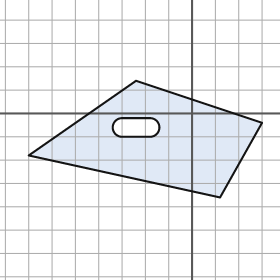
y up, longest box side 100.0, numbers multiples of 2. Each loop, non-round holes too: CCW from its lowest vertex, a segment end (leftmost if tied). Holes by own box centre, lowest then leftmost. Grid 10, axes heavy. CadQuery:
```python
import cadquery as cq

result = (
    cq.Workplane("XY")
    .moveTo(12.0, -36.0)
    .lineTo(30.0, -4.0)
    .lineTo(-24.0, 14.0)
    .lineTo(-70.0, -18.0)
    .close()
    .moveTo(-30.0, -10.0)
    .lineTo(-18.0, -10.0)
    .threePointArc((-14.0, -6.0), (-18.0, -2.0))
    .lineTo(-30.0, -2.0)
    .threePointArc((-34.0, -6.0), (-30.0, -10.0))
    .close()
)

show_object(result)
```